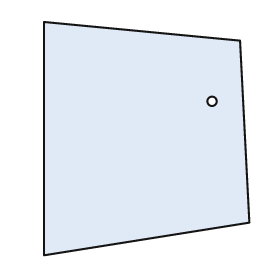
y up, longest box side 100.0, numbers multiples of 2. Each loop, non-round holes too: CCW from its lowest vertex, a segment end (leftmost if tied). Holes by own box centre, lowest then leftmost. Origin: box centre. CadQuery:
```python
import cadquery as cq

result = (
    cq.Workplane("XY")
    .moveTo(-44.0, -50.0)
    .lineTo(44.0, -36.0)
    .lineTo(40.0, 42.0)
    .lineTo(-44.0, 50.0)
    .close()
    .moveTo(28.0, 16.0)
    .circle(2.0)
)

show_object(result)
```